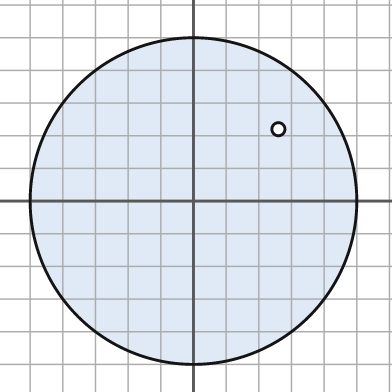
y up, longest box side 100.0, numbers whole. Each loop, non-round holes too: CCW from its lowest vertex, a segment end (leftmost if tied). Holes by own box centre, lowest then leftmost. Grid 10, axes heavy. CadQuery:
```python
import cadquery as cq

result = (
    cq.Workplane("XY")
    .moveTo(0.0, 0.0)
    .circle(50.0)
    .moveTo(26.0, 22.0)
    .circle(2.0)
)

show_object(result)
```